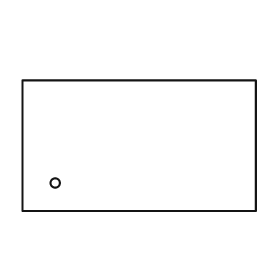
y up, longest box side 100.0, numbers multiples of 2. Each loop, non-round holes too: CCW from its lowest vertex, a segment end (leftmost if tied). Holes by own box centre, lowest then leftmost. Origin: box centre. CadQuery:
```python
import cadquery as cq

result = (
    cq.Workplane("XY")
    .moveTo(-50.0, -28.0)
    .lineTo(50.0, -28.0)
    .lineTo(50.0, 28.0)
    .lineTo(-50.0, 28.0)
    .close()
    .moveTo(-36.0, -16.0)
    .circle(2.0)
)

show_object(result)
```